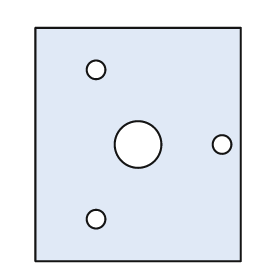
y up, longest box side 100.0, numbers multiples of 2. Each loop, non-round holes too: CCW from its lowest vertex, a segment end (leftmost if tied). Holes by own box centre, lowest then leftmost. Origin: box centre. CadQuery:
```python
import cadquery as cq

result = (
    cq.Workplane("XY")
    .moveTo(-44.0, -50.0)
    .lineTo(44.0, -50.0)
    .lineTo(44.0, 50.0)
    .lineTo(-44.0, 50.0)
    .close()
    .moveTo(-18.0, -32.0)
    .circle(4.0)
    .moveTo(0.0, 0.0)
    .circle(10.0)
    .moveTo(36.0, 0.0)
    .circle(4.0)
    .moveTo(-18.0, 32.0)
    .circle(4.0)
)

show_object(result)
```